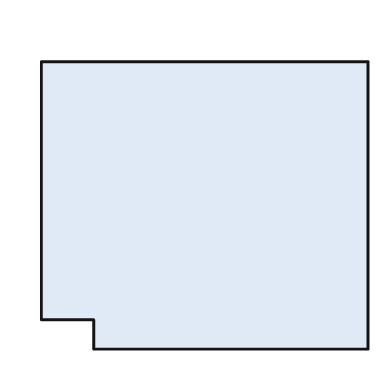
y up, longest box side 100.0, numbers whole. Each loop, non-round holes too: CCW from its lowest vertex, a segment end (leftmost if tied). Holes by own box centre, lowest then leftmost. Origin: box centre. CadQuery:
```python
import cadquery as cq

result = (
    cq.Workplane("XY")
    .moveTo(-34.0, -44.0)
    .lineTo(50.0, -44.0)
    .lineTo(50.0, 44.0)
    .lineTo(-50.0, 44.0)
    .lineTo(-50.0, -35.0)
    .lineTo(-34.0, -35.0)
    .close()
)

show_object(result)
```